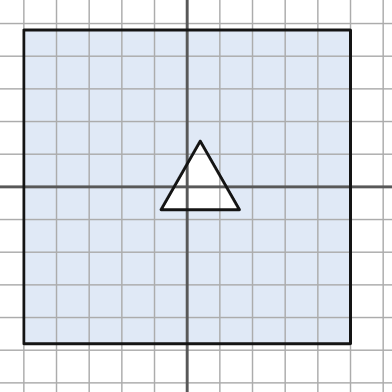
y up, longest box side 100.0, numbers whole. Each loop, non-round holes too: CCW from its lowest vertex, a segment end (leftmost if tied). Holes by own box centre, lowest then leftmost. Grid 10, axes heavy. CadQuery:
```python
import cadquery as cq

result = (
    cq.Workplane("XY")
    .moveTo(-50.0, -48.0)
    .lineTo(50.0, -48.0)
    .lineTo(50.0, 48.0)
    .lineTo(-50.0, 48.0)
    .close()
    .moveTo(-8.0, -7.0)
    .lineTo(16.0, -7.0)
    .lineTo(4.0, 14.0)
    .close()
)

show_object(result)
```